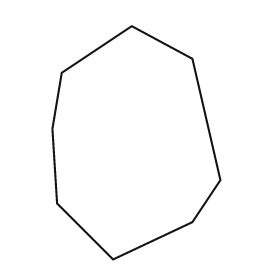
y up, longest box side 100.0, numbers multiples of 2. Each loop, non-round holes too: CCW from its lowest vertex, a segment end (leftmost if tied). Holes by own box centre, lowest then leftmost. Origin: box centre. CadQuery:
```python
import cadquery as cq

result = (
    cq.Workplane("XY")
    .moveTo(-10.0, -50.0)
    .lineTo(24.0, -34.0)
    .lineTo(36.0, -16.0)
    .lineTo(24.0, 36.0)
    .lineTo(-2.0, 50.0)
    .lineTo(-32.0, 30.0)
    .lineTo(-36.0, 6.0)
    .lineTo(-34.0, -26.0)
    .close()
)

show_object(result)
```